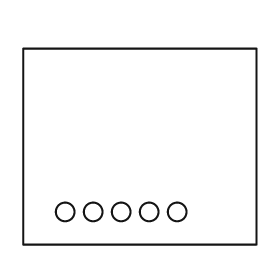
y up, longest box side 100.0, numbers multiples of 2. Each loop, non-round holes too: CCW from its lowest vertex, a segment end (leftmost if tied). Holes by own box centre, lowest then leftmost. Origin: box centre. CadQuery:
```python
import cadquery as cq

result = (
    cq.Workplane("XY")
    .moveTo(-50.0, -42.0)
    .lineTo(50.0, -42.0)
    .lineTo(50.0, 42.0)
    .lineTo(-50.0, 42.0)
    .close()
    .moveTo(-32.0, -28.0)
    .circle(4.0)
    .moveTo(-20.0, -28.0)
    .circle(4.0)
    .moveTo(-8.0, -28.0)
    .circle(4.0)
    .moveTo(4.0, -28.0)
    .circle(4.0)
    .moveTo(16.0, -28.0)
    .circle(4.0)
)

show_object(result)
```